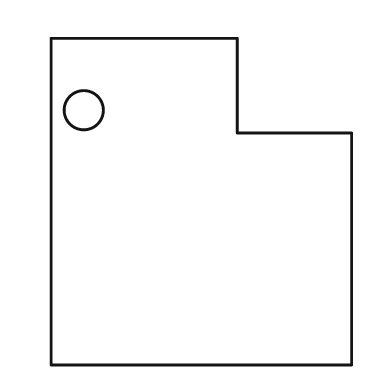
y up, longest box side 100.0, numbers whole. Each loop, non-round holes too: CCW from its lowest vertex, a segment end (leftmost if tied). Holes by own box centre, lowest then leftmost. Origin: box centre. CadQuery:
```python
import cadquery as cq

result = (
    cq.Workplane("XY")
    .moveTo(-46.0, -50.0)
    .lineTo(46.0, -50.0)
    .lineTo(46.0, 21.0)
    .lineTo(11.0, 21.0)
    .lineTo(11.0, 50.0)
    .lineTo(-46.0, 50.0)
    .close()
    .moveTo(-36.0, 28.0)
    .circle(6.0)
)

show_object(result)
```